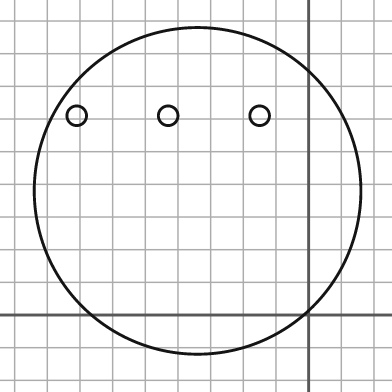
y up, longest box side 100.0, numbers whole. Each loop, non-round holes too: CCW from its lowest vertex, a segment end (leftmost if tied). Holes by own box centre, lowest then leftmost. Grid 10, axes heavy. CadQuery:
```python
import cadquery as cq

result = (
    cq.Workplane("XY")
    .moveTo(-34.0, 38.0)
    .circle(50.0)
    .moveTo(-71.0, 61.0)
    .circle(3.0)
    .moveTo(-43.0, 61.0)
    .circle(3.0)
    .moveTo(-15.0, 61.0)
    .circle(3.0)
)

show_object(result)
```